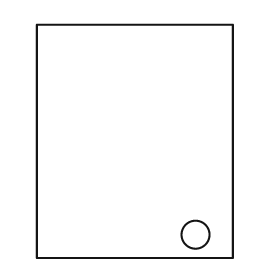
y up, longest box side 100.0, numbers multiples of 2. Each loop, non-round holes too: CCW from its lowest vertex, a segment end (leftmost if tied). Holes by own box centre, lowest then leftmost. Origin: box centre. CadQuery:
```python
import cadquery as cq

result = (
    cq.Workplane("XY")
    .moveTo(-42.0, -50.0)
    .lineTo(42.0, -50.0)
    .lineTo(42.0, 50.0)
    .lineTo(-42.0, 50.0)
    .close()
    .moveTo(26.0, -40.0)
    .circle(6.0)
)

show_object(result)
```